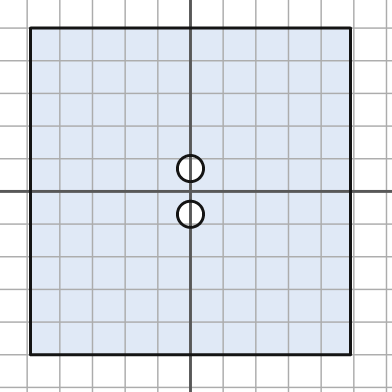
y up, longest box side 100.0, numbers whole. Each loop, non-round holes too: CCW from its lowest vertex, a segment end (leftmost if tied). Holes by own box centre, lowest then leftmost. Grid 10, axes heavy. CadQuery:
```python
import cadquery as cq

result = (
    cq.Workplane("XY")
    .moveTo(-49.0, -50.0)
    .lineTo(49.0, -50.0)
    .lineTo(49.0, 50.0)
    .lineTo(-49.0, 50.0)
    .close()
    .moveTo(0.0, -7.0)
    .circle(4.0)
    .moveTo(0.0, 7.0)
    .circle(4.0)
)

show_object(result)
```